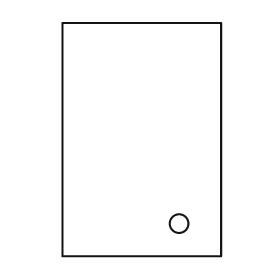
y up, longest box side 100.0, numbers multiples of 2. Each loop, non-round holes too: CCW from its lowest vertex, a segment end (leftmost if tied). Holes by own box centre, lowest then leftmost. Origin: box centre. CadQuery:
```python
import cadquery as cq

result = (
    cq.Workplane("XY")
    .moveTo(-34.0, -50.0)
    .lineTo(34.0, -50.0)
    .lineTo(34.0, 50.0)
    .lineTo(-34.0, 50.0)
    .close()
    .moveTo(16.0, -36.0)
    .circle(4.0)
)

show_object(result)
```